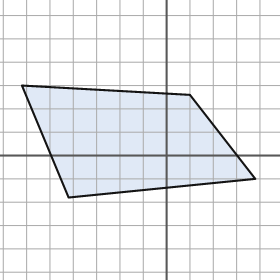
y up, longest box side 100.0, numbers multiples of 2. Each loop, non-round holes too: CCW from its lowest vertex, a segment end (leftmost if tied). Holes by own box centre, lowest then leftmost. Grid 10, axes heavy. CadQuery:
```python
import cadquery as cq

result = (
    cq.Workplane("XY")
    .moveTo(-42.0, -18.0)
    .lineTo(38.0, -10.0)
    .lineTo(10.0, 26.0)
    .lineTo(-62.0, 30.0)
    .close()
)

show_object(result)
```